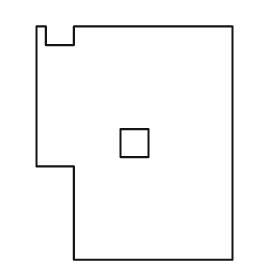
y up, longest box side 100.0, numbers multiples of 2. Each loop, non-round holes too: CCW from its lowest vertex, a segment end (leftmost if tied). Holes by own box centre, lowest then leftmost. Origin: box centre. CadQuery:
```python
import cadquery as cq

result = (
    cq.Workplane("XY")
    .moveTo(-26.0, -50.0)
    .lineTo(42.0, -50.0)
    .lineTo(42.0, 50.0)
    .lineTo(-26.0, 50.0)
    .lineTo(-26.0, 42.0)
    .lineTo(-38.0, 42.0)
    .lineTo(-38.0, 50.0)
    .lineTo(-42.0, 50.0)
    .lineTo(-42.0, -10.0)
    .lineTo(-26.0, -10.0)
    .close()
    .moveTo(-6.0, -6.0)
    .lineTo(6.0, -6.0)
    .lineTo(6.0, 6.0)
    .lineTo(-6.0, 6.0)
    .close()
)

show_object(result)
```